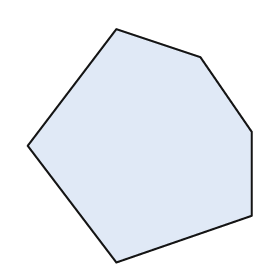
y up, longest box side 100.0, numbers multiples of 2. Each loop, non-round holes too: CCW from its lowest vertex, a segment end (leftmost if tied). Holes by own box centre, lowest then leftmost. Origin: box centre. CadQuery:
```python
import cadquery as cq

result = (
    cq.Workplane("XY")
    .moveTo(-10.0, -50.0)
    .lineTo(48.0, -30.0)
    .lineTo(48.0, 6.0)
    .lineTo(26.0, 38.0)
    .lineTo(-10.0, 50.0)
    .lineTo(-48.0, 0.0)
    .close()
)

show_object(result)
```